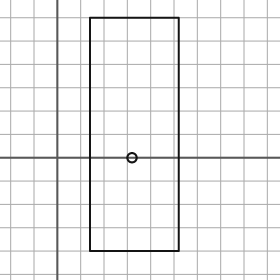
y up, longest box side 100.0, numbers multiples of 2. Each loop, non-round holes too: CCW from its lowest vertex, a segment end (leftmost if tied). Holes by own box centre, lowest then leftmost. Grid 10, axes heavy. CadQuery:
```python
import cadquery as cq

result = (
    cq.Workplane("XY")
    .moveTo(14.0, -40.0)
    .lineTo(52.0, -40.0)
    .lineTo(52.0, 60.0)
    .lineTo(14.0, 60.0)
    .close()
    .moveTo(32.0, 0.0)
    .circle(2.0)
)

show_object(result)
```